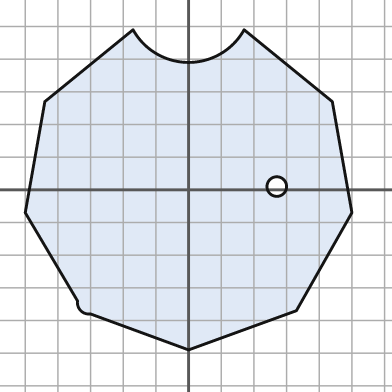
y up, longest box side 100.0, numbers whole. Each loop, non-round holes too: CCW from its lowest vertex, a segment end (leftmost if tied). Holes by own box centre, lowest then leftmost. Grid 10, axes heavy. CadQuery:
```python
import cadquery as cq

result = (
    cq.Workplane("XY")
    .moveTo(0.0, -49.0)
    .lineTo(33.0, -37.0)
    .lineTo(50.0, -7.0)
    .lineTo(44.0, 27.0)
    .lineTo(17.0, 49.0)
    .threePointArc((0.0, 39.0), (-17.0, 49.0))
    .lineTo(-44.0, 27.0)
    .lineTo(-50.0, -7.0)
    .lineTo(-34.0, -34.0)
    .threePointArc((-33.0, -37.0), (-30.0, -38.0))
    .close()
    .moveTo(27.0, 1.0)
    .circle(3.0)
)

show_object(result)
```